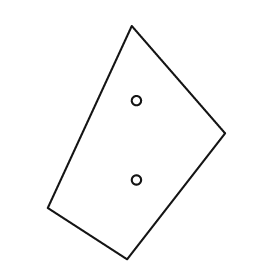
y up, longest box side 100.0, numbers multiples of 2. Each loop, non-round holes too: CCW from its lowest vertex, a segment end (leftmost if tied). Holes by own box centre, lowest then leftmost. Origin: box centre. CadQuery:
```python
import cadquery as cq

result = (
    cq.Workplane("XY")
    .moveTo(-4.0, -50.0)
    .lineTo(38.0, 4.0)
    .lineTo(-2.0, 50.0)
    .lineTo(-38.0, -28.0)
    .close()
    .moveTo(0.0, -16.0)
    .circle(2.0)
    .moveTo(0.0, 18.0)
    .circle(2.0)
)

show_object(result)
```